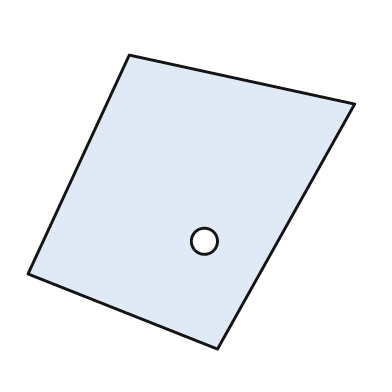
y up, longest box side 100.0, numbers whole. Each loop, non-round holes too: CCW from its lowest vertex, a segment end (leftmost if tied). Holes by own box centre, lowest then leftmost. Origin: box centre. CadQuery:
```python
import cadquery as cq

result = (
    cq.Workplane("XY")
    .moveTo(8.0, -45.0)
    .lineTo(50.0, 30.0)
    .lineTo(-19.0, 45.0)
    .lineTo(-50.0, -22.0)
    .close()
    .moveTo(4.0, -12.0)
    .circle(4.0)
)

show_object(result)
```